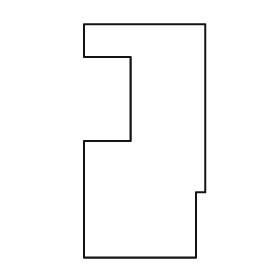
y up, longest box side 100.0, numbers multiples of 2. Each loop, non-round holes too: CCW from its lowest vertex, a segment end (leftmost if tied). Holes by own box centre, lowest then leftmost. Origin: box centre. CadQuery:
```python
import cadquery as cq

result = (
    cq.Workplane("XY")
    .moveTo(-26.0, -50.0)
    .lineTo(22.0, -50.0)
    .lineTo(22.0, -22.0)
    .lineTo(26.0, -22.0)
    .lineTo(26.0, 50.0)
    .lineTo(-26.0, 50.0)
    .lineTo(-26.0, 36.0)
    .lineTo(-6.0, 36.0)
    .lineTo(-6.0, 0.0)
    .lineTo(-26.0, 0.0)
    .close()
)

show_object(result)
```